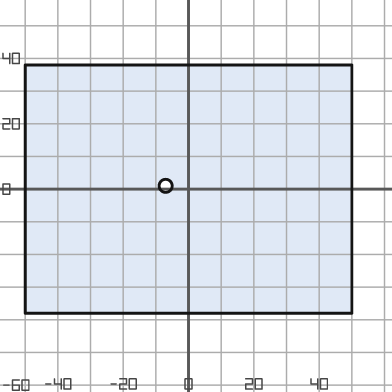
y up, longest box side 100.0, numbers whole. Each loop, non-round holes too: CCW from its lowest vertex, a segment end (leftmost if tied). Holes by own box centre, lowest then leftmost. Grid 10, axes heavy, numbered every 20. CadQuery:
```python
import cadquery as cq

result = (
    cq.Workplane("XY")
    .moveTo(-50.0, -38.0)
    .lineTo(50.0, -38.0)
    .lineTo(50.0, 38.0)
    .lineTo(-50.0, 38.0)
    .close()
    .moveTo(-7.0, 1.0)
    .circle(2.0)
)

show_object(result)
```